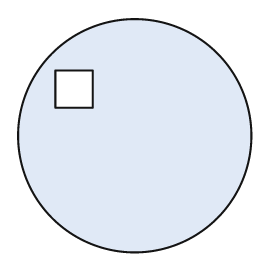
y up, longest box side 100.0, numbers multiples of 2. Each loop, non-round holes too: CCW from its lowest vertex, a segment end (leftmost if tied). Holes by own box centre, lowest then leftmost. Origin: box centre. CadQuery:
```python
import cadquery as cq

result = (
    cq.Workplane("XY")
    .moveTo(0.0, 0.0)
    .circle(50.0)
    .moveTo(-34.0, 12.0)
    .lineTo(-18.0, 12.0)
    .lineTo(-18.0, 28.0)
    .lineTo(-34.0, 28.0)
    .close()
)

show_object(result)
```